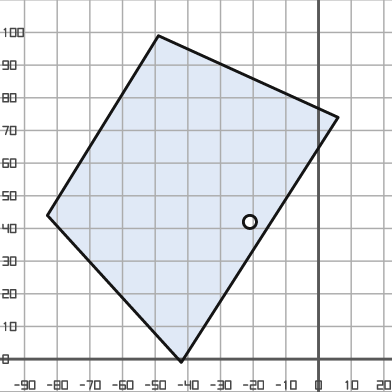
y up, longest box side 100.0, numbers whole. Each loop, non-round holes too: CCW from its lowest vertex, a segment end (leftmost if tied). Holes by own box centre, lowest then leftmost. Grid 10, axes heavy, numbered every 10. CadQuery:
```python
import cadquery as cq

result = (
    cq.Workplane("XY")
    .moveTo(-42.0, -1.0)
    .lineTo(6.0, 74.0)
    .lineTo(-49.0, 99.0)
    .lineTo(-83.0, 44.0)
    .close()
    .moveTo(-21.0, 42.0)
    .circle(2.0)
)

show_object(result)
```